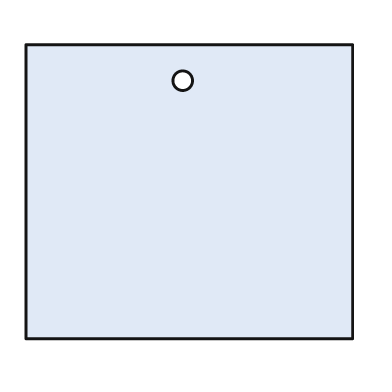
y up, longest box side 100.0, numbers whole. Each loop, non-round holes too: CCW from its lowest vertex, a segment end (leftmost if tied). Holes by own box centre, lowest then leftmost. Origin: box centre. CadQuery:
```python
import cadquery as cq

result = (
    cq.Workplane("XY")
    .moveTo(-50.0, -45.0)
    .lineTo(50.0, -45.0)
    .lineTo(50.0, 45.0)
    .lineTo(-50.0, 45.0)
    .close()
    .moveTo(-2.0, 34.0)
    .circle(3.0)
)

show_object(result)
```